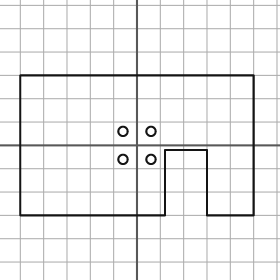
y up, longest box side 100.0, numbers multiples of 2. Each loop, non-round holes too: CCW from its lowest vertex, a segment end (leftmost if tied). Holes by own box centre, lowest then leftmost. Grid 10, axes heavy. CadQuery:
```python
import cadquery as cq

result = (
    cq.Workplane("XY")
    .moveTo(-50.0, -30.0)
    .lineTo(12.0, -30.0)
    .lineTo(12.0, -2.0)
    .lineTo(30.0, -2.0)
    .lineTo(30.0, -30.0)
    .lineTo(50.0, -30.0)
    .lineTo(50.0, 30.0)
    .lineTo(-50.0, 30.0)
    .close()
    .moveTo(-6.0, -6.0)
    .circle(2.0)
    .moveTo(6.0, -6.0)
    .circle(2.0)
    .moveTo(-6.0, 6.0)
    .circle(2.0)
    .moveTo(6.0, 6.0)
    .circle(2.0)
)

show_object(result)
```